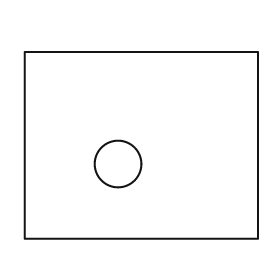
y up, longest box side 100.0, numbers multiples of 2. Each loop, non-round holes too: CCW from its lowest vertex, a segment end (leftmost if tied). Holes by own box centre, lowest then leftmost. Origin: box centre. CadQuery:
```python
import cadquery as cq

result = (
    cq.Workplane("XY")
    .moveTo(-50.0, -40.0)
    .lineTo(50.0, -40.0)
    .lineTo(50.0, 40.0)
    .lineTo(-50.0, 40.0)
    .close()
    .moveTo(-10.0, -8.0)
    .circle(10.0)
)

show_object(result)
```